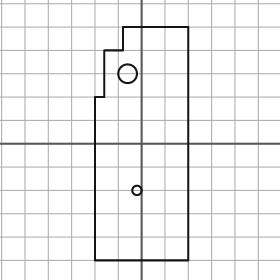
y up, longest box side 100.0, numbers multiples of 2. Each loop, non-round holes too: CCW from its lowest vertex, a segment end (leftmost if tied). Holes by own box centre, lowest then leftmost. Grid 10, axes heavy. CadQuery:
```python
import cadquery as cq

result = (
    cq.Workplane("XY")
    .moveTo(-20.0, -50.0)
    .lineTo(20.0, -50.0)
    .lineTo(20.0, 50.0)
    .lineTo(-8.0, 50.0)
    .lineTo(-8.0, 40.0)
    .lineTo(-16.0, 40.0)
    .lineTo(-16.0, 20.0)
    .lineTo(-20.0, 20.0)
    .close()
    .moveTo(-2.0, -20.0)
    .circle(2.0)
    .moveTo(-6.0, 30.0)
    .circle(4.0)
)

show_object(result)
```